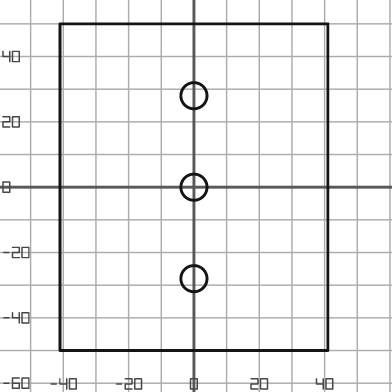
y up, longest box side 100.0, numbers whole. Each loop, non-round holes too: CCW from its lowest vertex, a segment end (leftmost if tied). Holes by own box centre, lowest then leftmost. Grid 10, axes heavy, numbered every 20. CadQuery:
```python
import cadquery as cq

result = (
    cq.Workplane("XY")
    .moveTo(-41.0, -50.0)
    .lineTo(41.0, -50.0)
    .lineTo(41.0, 50.0)
    .lineTo(-41.0, 50.0)
    .close()
    .moveTo(0.0, -28.0)
    .circle(4.0)
    .moveTo(0.0, 0.0)
    .circle(4.0)
    .moveTo(0.0, 28.0)
    .circle(4.0)
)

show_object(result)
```